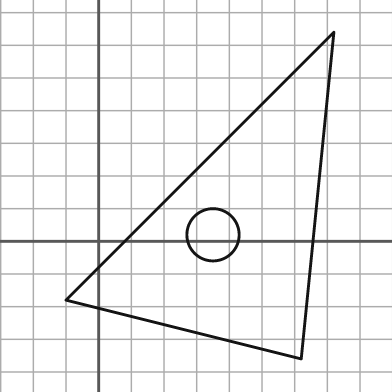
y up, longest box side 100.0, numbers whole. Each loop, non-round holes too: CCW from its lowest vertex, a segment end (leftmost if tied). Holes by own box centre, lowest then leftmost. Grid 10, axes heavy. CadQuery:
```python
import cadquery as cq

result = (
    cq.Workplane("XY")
    .moveTo(62.0, -36.0)
    .lineTo(72.0, 64.0)
    .lineTo(-10.0, -18.0)
    .close()
    .moveTo(35.0, 2.0)
    .circle(8.0)
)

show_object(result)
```